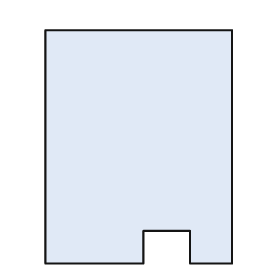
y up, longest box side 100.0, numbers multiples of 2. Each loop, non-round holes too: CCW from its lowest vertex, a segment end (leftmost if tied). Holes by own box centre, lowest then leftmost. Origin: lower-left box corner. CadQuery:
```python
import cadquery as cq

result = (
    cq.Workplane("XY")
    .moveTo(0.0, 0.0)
    .lineTo(42.0, 0.0)
    .lineTo(42.0, 14.0)
    .lineTo(62.0, 14.0)
    .lineTo(62.0, 0.0)
    .lineTo(80.0, 0.0)
    .lineTo(80.0, 100.0)
    .lineTo(0.0, 100.0)
    .close()
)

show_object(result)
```